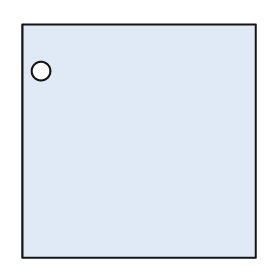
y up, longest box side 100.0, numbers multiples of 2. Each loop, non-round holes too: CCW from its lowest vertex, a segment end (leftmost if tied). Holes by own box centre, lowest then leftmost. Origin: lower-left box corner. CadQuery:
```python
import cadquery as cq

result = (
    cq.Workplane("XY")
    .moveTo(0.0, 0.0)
    .lineTo(100.0, 0.0)
    .lineTo(100.0, 100.0)
    .lineTo(0.0, 100.0)
    .close()
    .moveTo(8.0, 80.0)
    .circle(4.0)
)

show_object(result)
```